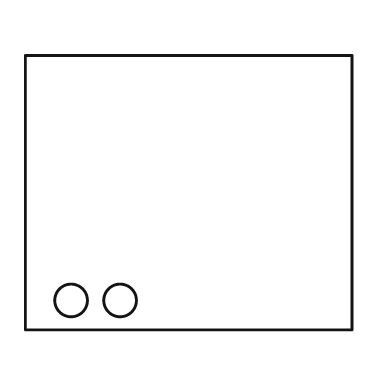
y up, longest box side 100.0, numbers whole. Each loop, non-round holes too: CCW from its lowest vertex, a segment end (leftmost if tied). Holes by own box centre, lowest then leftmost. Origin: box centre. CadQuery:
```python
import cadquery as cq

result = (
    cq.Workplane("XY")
    .moveTo(-50.0, -42.0)
    .lineTo(50.0, -42.0)
    .lineTo(50.0, 42.0)
    .lineTo(-50.0, 42.0)
    .close()
    .moveTo(-36.0, -33.0)
    .circle(5.0)
    .moveTo(-21.0, -33.0)
    .circle(5.0)
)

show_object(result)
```